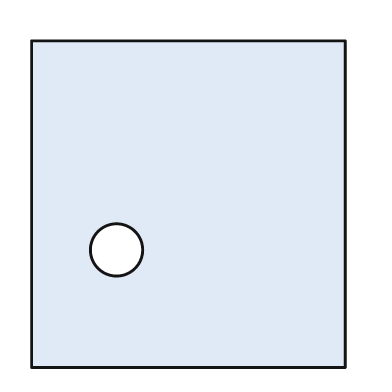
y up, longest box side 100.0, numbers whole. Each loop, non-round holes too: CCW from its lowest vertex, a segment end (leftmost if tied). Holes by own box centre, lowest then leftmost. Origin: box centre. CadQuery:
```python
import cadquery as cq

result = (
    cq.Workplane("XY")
    .moveTo(-48.0, -50.0)
    .lineTo(48.0, -50.0)
    .lineTo(48.0, 50.0)
    .lineTo(-48.0, 50.0)
    .close()
    .moveTo(-22.0, -14.0)
    .circle(8.0)
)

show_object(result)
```